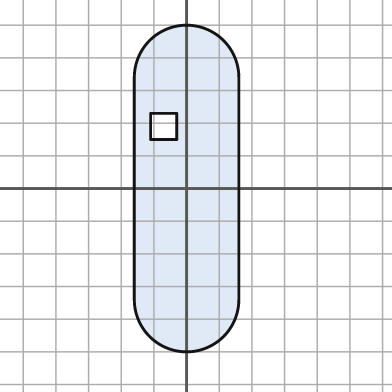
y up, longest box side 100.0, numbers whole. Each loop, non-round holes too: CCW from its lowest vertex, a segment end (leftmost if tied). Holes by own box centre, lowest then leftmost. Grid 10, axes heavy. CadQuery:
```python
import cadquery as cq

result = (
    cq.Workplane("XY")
    .moveTo(-16.0, -34.0)
    .threePointArc((0.0, -50.0), (16.0, -34.0))
    .lineTo(16.0, 34.0)
    .threePointArc((0.0, 50.0), (-16.0, 34.0))
    .close()
    .moveTo(-11.0, 15.0)
    .lineTo(-3.0, 15.0)
    .lineTo(-3.0, 23.0)
    .lineTo(-11.0, 23.0)
    .close()
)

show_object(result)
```